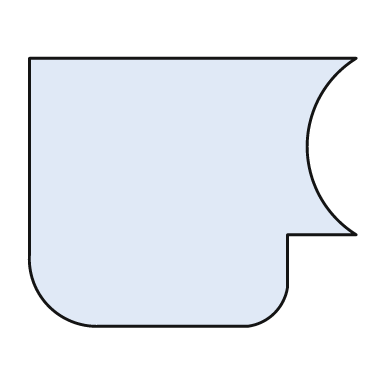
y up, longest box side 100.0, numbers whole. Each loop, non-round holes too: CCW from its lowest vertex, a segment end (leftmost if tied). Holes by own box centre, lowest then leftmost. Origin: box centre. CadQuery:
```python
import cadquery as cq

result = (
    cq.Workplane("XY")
    .moveTo(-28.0, -41.0)
    .lineTo(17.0, -41.0)
    .threePointArc((25.0, -37.0), (29.0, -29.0))
    .lineTo(29.0, -13.0)
    .lineTo(50.0, -13.0)
    .threePointArc((35.0, 14.0), (50.0, 41.0))
    .lineTo(-50.0, 41.0)
    .lineTo(-50.0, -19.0)
    .threePointArc((-44.0, -35.0), (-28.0, -41.0))
    .close()
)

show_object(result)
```